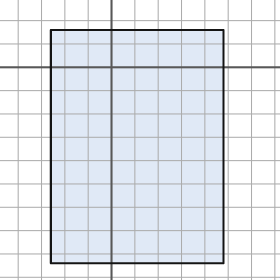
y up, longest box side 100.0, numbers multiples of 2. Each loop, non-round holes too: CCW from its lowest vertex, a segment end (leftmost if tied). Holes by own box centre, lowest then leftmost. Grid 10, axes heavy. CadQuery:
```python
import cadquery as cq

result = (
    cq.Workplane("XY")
    .moveTo(-26.0, -84.0)
    .lineTo(48.0, -84.0)
    .lineTo(48.0, 16.0)
    .lineTo(-26.0, 16.0)
    .close()
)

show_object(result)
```